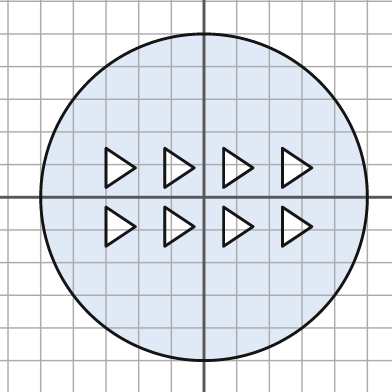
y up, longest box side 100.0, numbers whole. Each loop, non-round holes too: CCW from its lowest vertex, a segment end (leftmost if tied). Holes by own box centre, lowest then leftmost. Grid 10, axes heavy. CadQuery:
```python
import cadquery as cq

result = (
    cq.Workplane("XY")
    .moveTo(0.0, 0.0)
    .circle(50.0)
    .moveTo(-30.0, -15.0)
    .lineTo(-21.0, -9.0)
    .lineTo(-30.0, -3.0)
    .close()
    .moveTo(-12.0, -15.0)
    .lineTo(-3.0, -9.0)
    .lineTo(-12.0, -3.0)
    .close()
    .moveTo(6.0, -15.0)
    .lineTo(15.0, -9.0)
    .lineTo(6.0, -3.0)
    .close()
    .moveTo(24.0, -15.0)
    .lineTo(33.0, -9.0)
    .lineTo(24.0, -3.0)
    .close()
    .moveTo(-30.0, 3.0)
    .lineTo(-21.0, 9.0)
    .lineTo(-30.0, 15.0)
    .close()
    .moveTo(-12.0, 3.0)
    .lineTo(-3.0, 9.0)
    .lineTo(-12.0, 15.0)
    .close()
    .moveTo(6.0, 3.0)
    .lineTo(15.0, 9.0)
    .lineTo(6.0, 15.0)
    .close()
    .moveTo(24.0, 3.0)
    .lineTo(33.0, 9.0)
    .lineTo(24.0, 15.0)
    .close()
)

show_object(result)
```